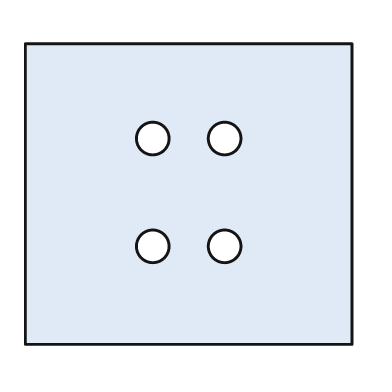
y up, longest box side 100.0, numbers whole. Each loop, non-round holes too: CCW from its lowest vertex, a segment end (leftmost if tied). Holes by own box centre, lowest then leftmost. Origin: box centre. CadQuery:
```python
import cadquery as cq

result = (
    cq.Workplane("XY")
    .moveTo(-50.0, -46.0)
    .lineTo(50.0, -46.0)
    .lineTo(50.0, 46.0)
    .lineTo(-50.0, 46.0)
    .close()
    .moveTo(-11.0, -16.0)
    .circle(5.0)
    .moveTo(11.0, -16.0)
    .circle(5.0)
    .moveTo(-11.0, 17.0)
    .circle(5.0)
    .moveTo(11.0, 17.0)
    .circle(5.0)
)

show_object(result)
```